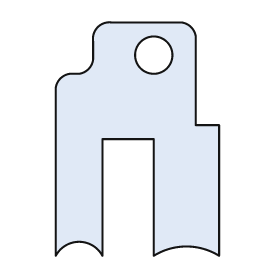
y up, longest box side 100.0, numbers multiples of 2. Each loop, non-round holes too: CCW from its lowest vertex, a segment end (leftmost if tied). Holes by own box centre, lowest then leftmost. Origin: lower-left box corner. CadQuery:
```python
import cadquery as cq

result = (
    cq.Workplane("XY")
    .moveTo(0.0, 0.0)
    .threePointArc((10.0, 6.0), (20.0, 0.0))
    .lineTo(20.0, 50.0)
    .lineTo(42.0, 50.0)
    .lineTo(42.0, 0.0)
    .threePointArc((56.0, 4.0), (70.0, 0.0))
    .lineTo(70.0, 56.0)
    .lineTo(60.0, 56.0)
    .lineTo(60.0, 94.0)
    .threePointArc((58.0, 98.0), (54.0, 100.0))
    .lineTo(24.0, 100.0)
    .threePointArc((18.0, 98.0), (16.0, 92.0))
    .lineTo(16.0, 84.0)
    .threePointArc((14.0, 80.0), (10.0, 78.0))
    .lineTo(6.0, 78.0)
    .threePointArc((2.0, 76.0), (0.0, 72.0))
    .close()
    .moveTo(42.0, 86.0)
    .circle(8.0)
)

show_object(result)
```